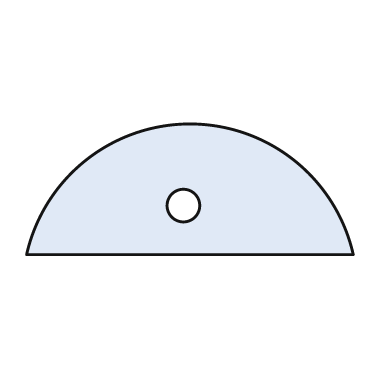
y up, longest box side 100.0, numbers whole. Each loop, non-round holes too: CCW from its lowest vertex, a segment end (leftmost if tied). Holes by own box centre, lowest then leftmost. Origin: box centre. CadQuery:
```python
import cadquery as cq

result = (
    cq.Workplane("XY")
    .moveTo(-50.0, -20.0)
    .lineTo(50.0, -20.0)
    .threePointArc((0.0, 20.0), (-50.0, -20.0))
    .close()
    .moveTo(-2.0, -5.0)
    .circle(5.0)
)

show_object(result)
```